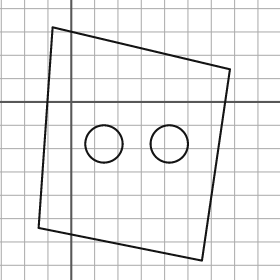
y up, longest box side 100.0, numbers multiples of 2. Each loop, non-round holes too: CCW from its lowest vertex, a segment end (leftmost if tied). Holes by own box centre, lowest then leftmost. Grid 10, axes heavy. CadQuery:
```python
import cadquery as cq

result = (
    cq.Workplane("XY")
    .moveTo(56.0, -68.0)
    .lineTo(68.0, 14.0)
    .lineTo(-8.0, 32.0)
    .lineTo(-14.0, -54.0)
    .close()
    .moveTo(14.0, -18.0)
    .circle(8.0)
    .moveTo(42.0, -18.0)
    .circle(8.0)
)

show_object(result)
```